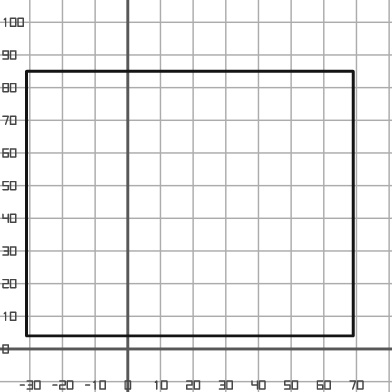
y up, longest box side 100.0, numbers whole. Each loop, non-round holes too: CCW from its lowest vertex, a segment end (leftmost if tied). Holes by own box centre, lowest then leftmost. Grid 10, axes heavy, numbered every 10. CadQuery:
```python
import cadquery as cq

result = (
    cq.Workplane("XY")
    .moveTo(-31.0, 4.0)
    .lineTo(69.0, 4.0)
    .lineTo(69.0, 85.0)
    .lineTo(-31.0, 85.0)
    .close()
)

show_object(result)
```